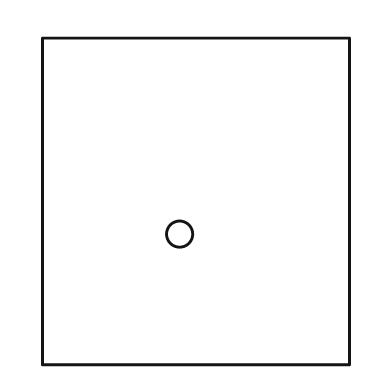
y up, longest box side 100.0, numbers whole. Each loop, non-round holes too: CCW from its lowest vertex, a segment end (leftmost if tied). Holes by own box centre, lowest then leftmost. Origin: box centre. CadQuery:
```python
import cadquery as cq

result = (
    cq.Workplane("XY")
    .moveTo(-47.0, -50.0)
    .lineTo(47.0, -50.0)
    .lineTo(47.0, 50.0)
    .lineTo(-47.0, 50.0)
    .close()
    .moveTo(-5.0, -10.0)
    .circle(4.0)
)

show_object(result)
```